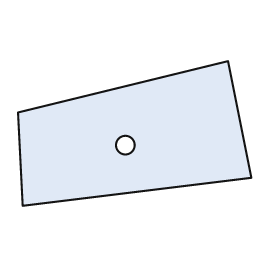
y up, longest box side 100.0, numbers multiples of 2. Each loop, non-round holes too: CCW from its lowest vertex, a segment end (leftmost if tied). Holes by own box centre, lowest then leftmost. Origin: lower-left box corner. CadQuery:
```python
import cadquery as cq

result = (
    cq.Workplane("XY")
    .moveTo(2.0, 0.0)
    .lineTo(100.0, 12.0)
    .lineTo(90.0, 62.0)
    .lineTo(0.0, 40.0)
    .close()
    .moveTo(46.0, 26.0)
    .circle(4.0)
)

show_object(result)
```